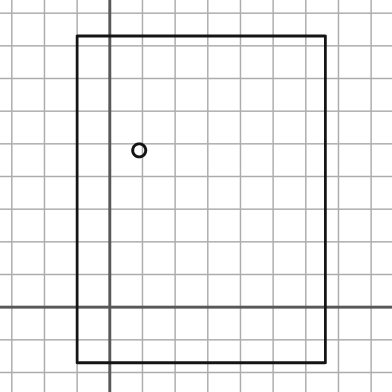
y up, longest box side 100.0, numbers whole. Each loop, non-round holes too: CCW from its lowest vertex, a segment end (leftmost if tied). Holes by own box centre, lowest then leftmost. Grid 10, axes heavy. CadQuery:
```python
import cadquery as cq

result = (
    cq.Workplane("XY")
    .moveTo(-10.0, -17.0)
    .lineTo(66.0, -17.0)
    .lineTo(66.0, 83.0)
    .lineTo(-10.0, 83.0)
    .close()
    .moveTo(9.0, 48.0)
    .circle(2.0)
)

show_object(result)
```